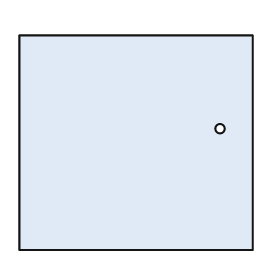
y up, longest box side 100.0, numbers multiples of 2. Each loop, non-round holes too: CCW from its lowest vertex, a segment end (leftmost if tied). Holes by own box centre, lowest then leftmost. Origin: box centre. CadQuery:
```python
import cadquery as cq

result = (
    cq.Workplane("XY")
    .moveTo(-50.0, -46.0)
    .lineTo(50.0, -46.0)
    .lineTo(50.0, 46.0)
    .lineTo(-50.0, 46.0)
    .close()
    .moveTo(36.0, 6.0)
    .circle(2.0)
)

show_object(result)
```